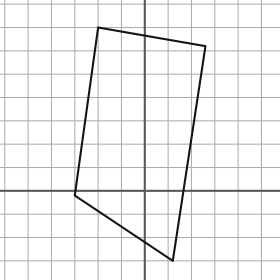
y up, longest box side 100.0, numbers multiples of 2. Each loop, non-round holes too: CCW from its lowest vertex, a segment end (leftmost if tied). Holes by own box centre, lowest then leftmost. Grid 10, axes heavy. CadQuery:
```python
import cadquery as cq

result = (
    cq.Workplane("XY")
    .moveTo(12.0, -30.0)
    .lineTo(26.0, 62.0)
    .lineTo(-20.0, 70.0)
    .lineTo(-30.0, -2.0)
    .close()
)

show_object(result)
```